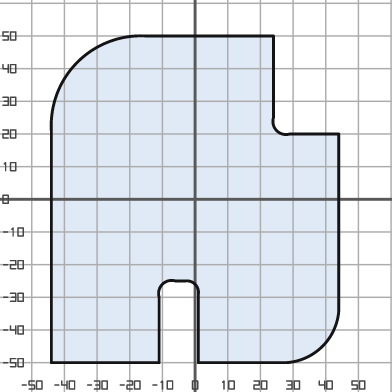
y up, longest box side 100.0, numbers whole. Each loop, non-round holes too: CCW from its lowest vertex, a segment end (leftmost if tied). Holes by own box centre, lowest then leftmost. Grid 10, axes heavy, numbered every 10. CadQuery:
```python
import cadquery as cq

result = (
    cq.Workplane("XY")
    .moveTo(-44.0, -50.0)
    .lineTo(-11.0, -50.0)
    .lineTo(-11.0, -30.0)
    .threePointArc((-10.0, -26.0), (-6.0, -25.0))
    .lineTo(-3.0, -25.0)
    .threePointArc((0.0, -26.0), (1.0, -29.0))
    .lineTo(1.0, -50.0)
    .lineTo(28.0, -50.0)
    .threePointArc((39.0, -45.0), (44.0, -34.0))
    .lineTo(44.0, 20.0)
    .lineTo(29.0, 20.0)
    .threePointArc((25.0, 21.0), (24.0, 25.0))
    .lineTo(24.0, 50.0)
    .lineTo(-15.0, 50.0)
    .threePointArc((-36.0, 42.0), (-44.0, 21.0))
    .close()
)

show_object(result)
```